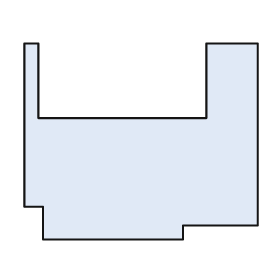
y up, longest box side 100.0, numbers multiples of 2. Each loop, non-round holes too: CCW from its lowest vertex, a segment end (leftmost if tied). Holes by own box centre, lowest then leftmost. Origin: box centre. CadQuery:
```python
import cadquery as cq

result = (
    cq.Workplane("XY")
    .moveTo(-42.0, -42.0)
    .lineTo(18.0, -42.0)
    .lineTo(18.0, -36.0)
    .lineTo(50.0, -36.0)
    .lineTo(50.0, 42.0)
    .lineTo(28.0, 42.0)
    .lineTo(28.0, 10.0)
    .lineTo(-44.0, 10.0)
    .lineTo(-44.0, 42.0)
    .lineTo(-50.0, 42.0)
    .lineTo(-50.0, -28.0)
    .lineTo(-42.0, -28.0)
    .close()
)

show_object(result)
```